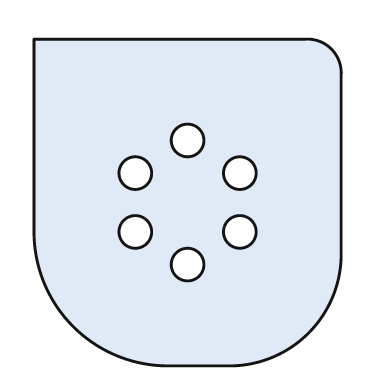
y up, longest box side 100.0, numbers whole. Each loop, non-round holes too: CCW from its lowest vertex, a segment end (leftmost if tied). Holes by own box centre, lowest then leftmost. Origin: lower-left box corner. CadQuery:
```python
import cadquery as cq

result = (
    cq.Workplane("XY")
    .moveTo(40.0, 0.0)
    .lineTo(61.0, 0.0)
    .threePointArc((84.0, 10.0), (94.0, 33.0))
    .lineTo(94.0, 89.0)
    .threePointArc((91.0, 97.0), (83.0, 100.0))
    .lineTo(0.0, 100.0)
    .lineTo(0.0, 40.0)
    .threePointArc((12.0, 12.0), (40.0, 0.0))
    .close()
    .moveTo(47.0, 31.0)
    .circle(5.0)
    .moveTo(31.0, 41.0)
    .circle(5.0)
    .moveTo(63.0, 41.0)
    .circle(5.0)
    .moveTo(31.0, 59.0)
    .circle(5.0)
    .moveTo(63.0, 59.0)
    .circle(5.0)
    .moveTo(47.0, 69.0)
    .circle(5.0)
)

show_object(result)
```